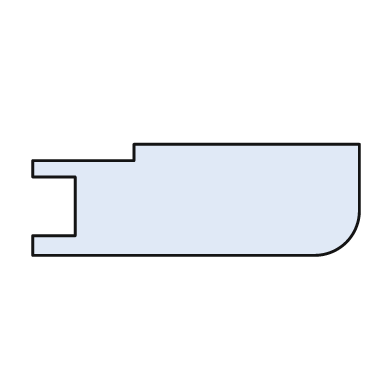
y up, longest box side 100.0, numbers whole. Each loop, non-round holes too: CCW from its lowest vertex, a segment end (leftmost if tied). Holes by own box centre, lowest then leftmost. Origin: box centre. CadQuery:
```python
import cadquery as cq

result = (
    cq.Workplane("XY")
    .moveTo(-50.0, -17.0)
    .lineTo(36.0, -17.0)
    .threePointArc((46.0, -13.0), (50.0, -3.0))
    .lineTo(50.0, 17.0)
    .lineTo(-19.0, 17.0)
    .lineTo(-19.0, 12.0)
    .lineTo(-50.0, 12.0)
    .lineTo(-50.0, 7.0)
    .lineTo(-37.0, 7.0)
    .lineTo(-37.0, -11.0)
    .lineTo(-50.0, -11.0)
    .close()
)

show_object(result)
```